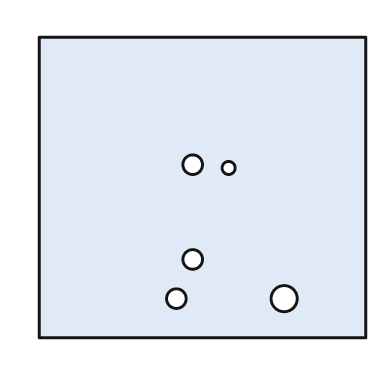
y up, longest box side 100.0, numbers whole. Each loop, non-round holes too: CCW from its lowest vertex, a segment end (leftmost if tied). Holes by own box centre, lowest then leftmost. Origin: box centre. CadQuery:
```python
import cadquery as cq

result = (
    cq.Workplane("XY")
    .moveTo(-50.0, -46.0)
    .lineTo(50.0, -46.0)
    .lineTo(50.0, 46.0)
    .lineTo(-50.0, 46.0)
    .close()
    .moveTo(-8.0, -34.0)
    .circle(3.0)
    .moveTo(25.0, -34.0)
    .circle(4.0)
    .moveTo(-3.0, -22.0)
    .circle(3.0)
    .moveTo(8.0, 6.0)
    .circle(2.0)
    .moveTo(-3.0, 7.0)
    .circle(3.0)
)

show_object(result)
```